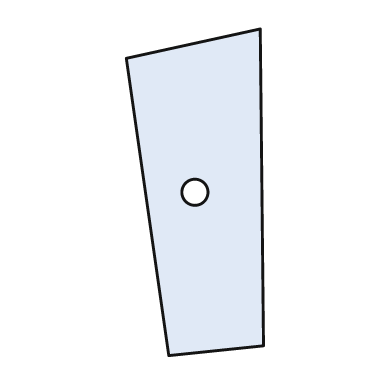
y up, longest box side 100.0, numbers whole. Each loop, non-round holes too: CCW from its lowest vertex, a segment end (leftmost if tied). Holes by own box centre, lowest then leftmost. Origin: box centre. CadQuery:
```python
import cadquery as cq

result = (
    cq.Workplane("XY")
    .moveTo(-8.0, -50.0)
    .lineTo(21.0, -47.0)
    .lineTo(20.0, 50.0)
    .lineTo(-21.0, 41.0)
    .close()
    .moveTo(0.0, 0.0)
    .circle(4.0)
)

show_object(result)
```